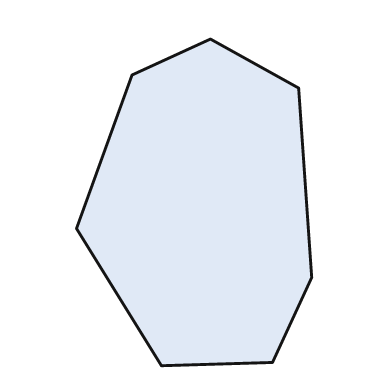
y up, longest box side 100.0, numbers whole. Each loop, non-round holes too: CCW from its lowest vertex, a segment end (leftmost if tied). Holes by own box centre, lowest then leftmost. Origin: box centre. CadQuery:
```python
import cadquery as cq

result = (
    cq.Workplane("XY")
    .moveTo(-10.0, -50.0)
    .lineTo(24.0, -49.0)
    .lineTo(36.0, -23.0)
    .lineTo(32.0, 35.0)
    .lineTo(5.0, 50.0)
    .lineTo(-19.0, 39.0)
    .lineTo(-36.0, -8.0)
    .close()
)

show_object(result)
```